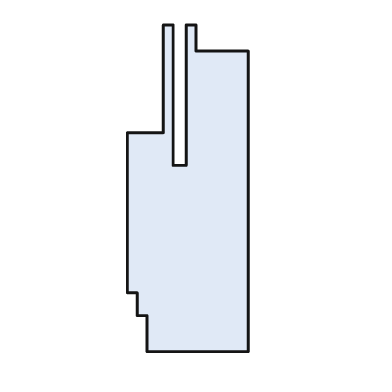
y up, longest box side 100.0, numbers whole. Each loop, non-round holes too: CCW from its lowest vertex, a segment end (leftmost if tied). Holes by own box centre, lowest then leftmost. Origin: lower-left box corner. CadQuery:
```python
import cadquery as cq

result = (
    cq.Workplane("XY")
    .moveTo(6.0, 0.0)
    .lineTo(37.0, 0.0)
    .lineTo(37.0, 92.0)
    .lineTo(21.0, 92.0)
    .lineTo(21.0, 100.0)
    .lineTo(18.0, 100.0)
    .lineTo(18.0, 57.0)
    .lineTo(14.0, 57.0)
    .lineTo(14.0, 100.0)
    .lineTo(11.0, 100.0)
    .lineTo(11.0, 67.0)
    .lineTo(0.0, 67.0)
    .lineTo(0.0, 18.0)
    .lineTo(3.0, 18.0)
    .lineTo(3.0, 11.0)
    .lineTo(6.0, 11.0)
    .close()
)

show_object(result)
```